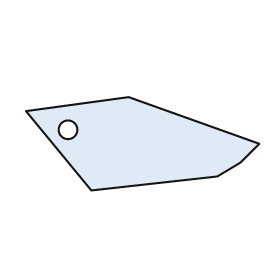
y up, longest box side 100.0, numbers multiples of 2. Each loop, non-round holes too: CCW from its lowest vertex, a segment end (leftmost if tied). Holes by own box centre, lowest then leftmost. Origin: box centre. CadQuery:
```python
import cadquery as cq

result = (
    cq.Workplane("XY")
    .moveTo(-22.0, -20.0)
    .lineTo(32.0, -14.0)
    .lineTo(42.0, -8.0)
    .lineTo(50.0, 0.0)
    .lineTo(-6.0, 20.0)
    .lineTo(-50.0, 14.0)
    .close()
    .moveTo(-32.0, 6.0)
    .circle(4.0)
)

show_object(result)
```